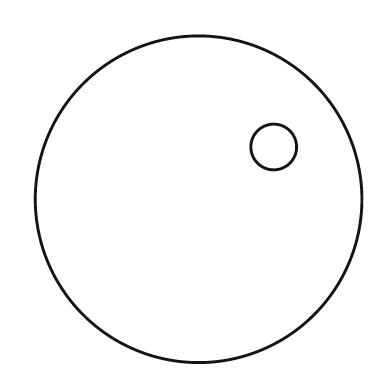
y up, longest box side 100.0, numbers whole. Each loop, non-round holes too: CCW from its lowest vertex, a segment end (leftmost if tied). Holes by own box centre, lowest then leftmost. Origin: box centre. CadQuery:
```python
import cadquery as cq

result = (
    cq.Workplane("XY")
    .moveTo(0.0, 0.0)
    .circle(50.0)
    .moveTo(23.0, 16.0)
    .circle(7.0)
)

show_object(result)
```